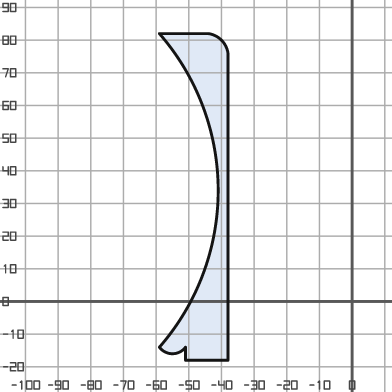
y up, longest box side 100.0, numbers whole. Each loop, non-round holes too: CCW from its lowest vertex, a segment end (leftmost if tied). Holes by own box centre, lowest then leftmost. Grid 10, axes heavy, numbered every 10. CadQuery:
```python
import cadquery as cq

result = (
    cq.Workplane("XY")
    .moveTo(-51.0, -18.0)
    .lineTo(-38.0, -18.0)
    .lineTo(-38.0, 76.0)
    .threePointArc((-40.0, 80.0), (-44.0, 82.0))
    .lineTo(-59.0, 82.0)
    .threePointArc((-41.0, 34.0), (-59.0, -14.0))
    .threePointArc((-55.0, -16.0), (-51.0, -14.0))
    .close()
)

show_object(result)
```